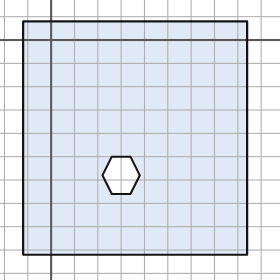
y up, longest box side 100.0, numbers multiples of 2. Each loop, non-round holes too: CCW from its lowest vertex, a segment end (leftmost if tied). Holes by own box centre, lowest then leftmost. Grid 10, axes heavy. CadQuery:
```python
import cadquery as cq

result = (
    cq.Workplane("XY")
    .moveTo(-12.0, -92.0)
    .lineTo(84.0, -92.0)
    .lineTo(84.0, 8.0)
    .lineTo(-12.0, 8.0)
    .close()
    .moveTo(26.0, -66.0)
    .lineTo(34.0, -66.0)
    .lineTo(38.0, -58.0)
    .lineTo(34.0, -50.0)
    .lineTo(26.0, -50.0)
    .lineTo(22.0, -58.0)
    .close()
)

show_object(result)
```